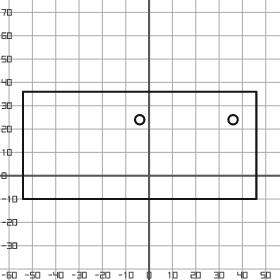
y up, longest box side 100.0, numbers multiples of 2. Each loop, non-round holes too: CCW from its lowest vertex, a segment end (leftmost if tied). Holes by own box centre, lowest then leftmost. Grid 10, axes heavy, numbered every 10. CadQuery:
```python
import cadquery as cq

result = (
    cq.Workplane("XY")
    .moveTo(-54.0, -10.0)
    .lineTo(46.0, -10.0)
    .lineTo(46.0, 36.0)
    .lineTo(-54.0, 36.0)
    .close()
    .moveTo(-4.0, 24.0)
    .circle(2.0)
    .moveTo(36.0, 24.0)
    .circle(2.0)
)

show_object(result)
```